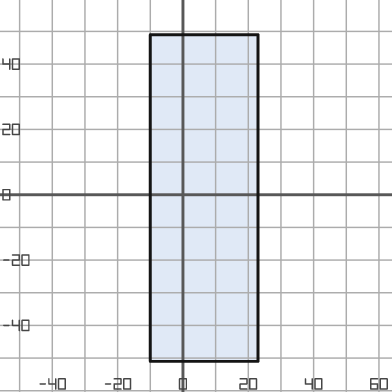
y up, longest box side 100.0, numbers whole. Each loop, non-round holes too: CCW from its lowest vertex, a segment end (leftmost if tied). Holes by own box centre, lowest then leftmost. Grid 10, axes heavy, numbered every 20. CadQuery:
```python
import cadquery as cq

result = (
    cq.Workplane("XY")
    .moveTo(-10.0, -51.0)
    .lineTo(23.0, -51.0)
    .lineTo(23.0, 49.0)
    .lineTo(-10.0, 49.0)
    .close()
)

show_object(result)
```